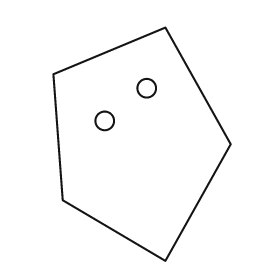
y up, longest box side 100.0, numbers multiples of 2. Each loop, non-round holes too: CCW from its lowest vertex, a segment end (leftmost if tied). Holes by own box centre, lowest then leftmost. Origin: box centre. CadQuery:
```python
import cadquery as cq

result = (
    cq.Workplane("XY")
    .moveTo(10.0, -50.0)
    .lineTo(38.0, 0.0)
    .lineTo(10.0, 50.0)
    .lineTo(-38.0, 30.0)
    .lineTo(-34.0, -24.0)
    .close()
    .moveTo(-16.0, 10.0)
    .circle(4.0)
    .moveTo(2.0, 24.0)
    .circle(4.0)
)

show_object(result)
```